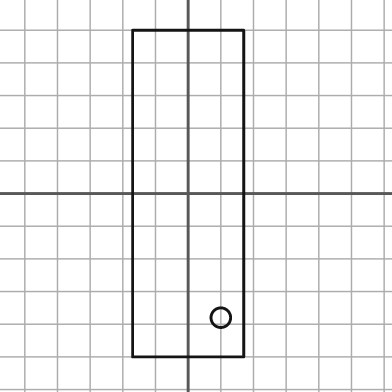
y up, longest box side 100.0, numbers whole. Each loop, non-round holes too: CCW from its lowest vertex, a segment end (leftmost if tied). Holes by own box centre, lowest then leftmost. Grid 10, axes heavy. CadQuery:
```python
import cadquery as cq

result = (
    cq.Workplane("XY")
    .moveTo(-17.0, -50.0)
    .lineTo(17.0, -50.0)
    .lineTo(17.0, 50.0)
    .lineTo(-17.0, 50.0)
    .close()
    .moveTo(10.0, -38.0)
    .circle(3.0)
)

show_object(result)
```